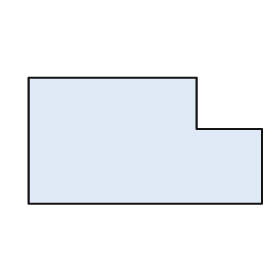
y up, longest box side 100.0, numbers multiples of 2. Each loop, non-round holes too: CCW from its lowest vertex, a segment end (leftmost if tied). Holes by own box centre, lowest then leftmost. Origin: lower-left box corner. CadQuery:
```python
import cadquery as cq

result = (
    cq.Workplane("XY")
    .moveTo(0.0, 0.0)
    .lineTo(100.0, 0.0)
    .lineTo(100.0, 32.0)
    .lineTo(72.0, 32.0)
    .lineTo(72.0, 54.0)
    .lineTo(0.0, 54.0)
    .close()
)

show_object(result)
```